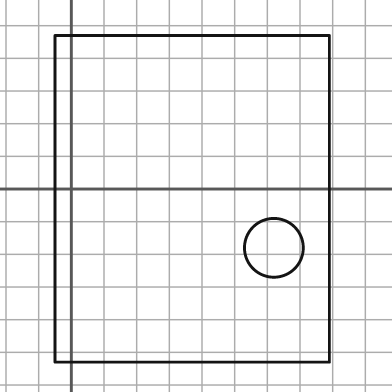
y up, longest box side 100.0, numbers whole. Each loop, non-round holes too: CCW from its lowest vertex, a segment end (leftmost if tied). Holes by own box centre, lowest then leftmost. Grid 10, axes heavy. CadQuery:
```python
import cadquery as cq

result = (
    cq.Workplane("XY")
    .moveTo(-5.0, -53.0)
    .lineTo(79.0, -53.0)
    .lineTo(79.0, 47.0)
    .lineTo(-5.0, 47.0)
    .close()
    .moveTo(62.0, -18.0)
    .circle(9.0)
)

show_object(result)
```